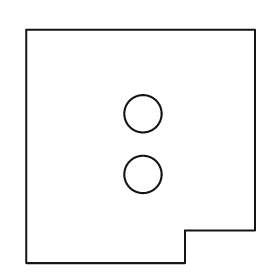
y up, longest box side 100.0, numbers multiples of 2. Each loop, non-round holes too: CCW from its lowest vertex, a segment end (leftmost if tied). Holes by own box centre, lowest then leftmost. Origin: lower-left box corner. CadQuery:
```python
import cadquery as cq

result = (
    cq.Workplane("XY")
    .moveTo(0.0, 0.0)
    .lineTo(68.0, 0.0)
    .lineTo(68.0, 14.0)
    .lineTo(98.0, 14.0)
    .lineTo(98.0, 100.0)
    .lineTo(0.0, 100.0)
    .close()
    .moveTo(50.0, 38.0)
    .circle(8.0)
    .moveTo(50.0, 64.0)
    .circle(8.0)
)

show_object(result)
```